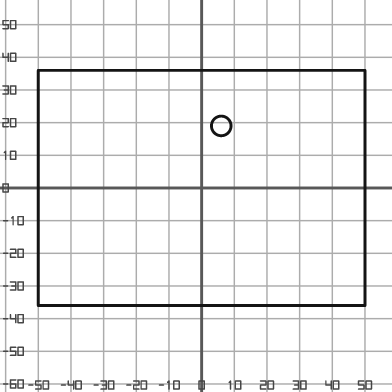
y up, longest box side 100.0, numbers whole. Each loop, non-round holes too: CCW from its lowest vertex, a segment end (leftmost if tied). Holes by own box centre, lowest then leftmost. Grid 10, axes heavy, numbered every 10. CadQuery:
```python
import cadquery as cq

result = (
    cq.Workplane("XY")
    .moveTo(-50.0, -36.0)
    .lineTo(50.0, -36.0)
    .lineTo(50.0, 36.0)
    .lineTo(-50.0, 36.0)
    .close()
    .moveTo(6.0, 19.0)
    .circle(3.0)
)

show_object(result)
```